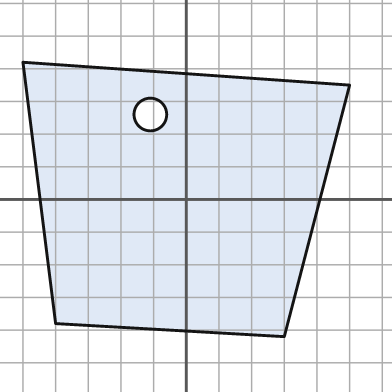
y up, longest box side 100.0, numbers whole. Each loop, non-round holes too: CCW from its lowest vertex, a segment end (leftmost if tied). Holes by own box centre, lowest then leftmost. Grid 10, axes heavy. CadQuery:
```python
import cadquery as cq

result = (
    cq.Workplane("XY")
    .moveTo(30.0, -42.0)
    .lineTo(50.0, 35.0)
    .lineTo(-50.0, 42.0)
    .lineTo(-40.0, -38.0)
    .close()
    .moveTo(-11.0, 26.0)
    .circle(5.0)
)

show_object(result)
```